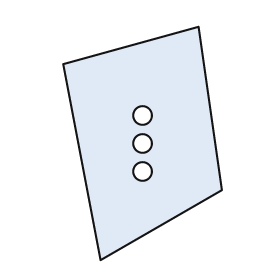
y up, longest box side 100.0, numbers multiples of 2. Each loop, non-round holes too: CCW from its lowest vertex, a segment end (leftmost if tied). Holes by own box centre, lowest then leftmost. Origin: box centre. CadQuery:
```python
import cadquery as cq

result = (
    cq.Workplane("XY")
    .moveTo(-18.0, -50.0)
    .lineTo(34.0, -20.0)
    .lineTo(24.0, 50.0)
    .lineTo(-34.0, 34.0)
    .close()
    .moveTo(0.0, -12.0)
    .circle(4.0)
    .moveTo(0.0, 0.0)
    .circle(4.0)
    .moveTo(0.0, 12.0)
    .circle(4.0)
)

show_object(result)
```